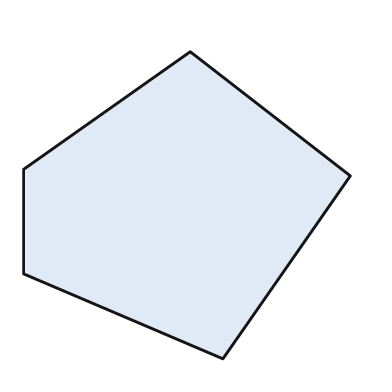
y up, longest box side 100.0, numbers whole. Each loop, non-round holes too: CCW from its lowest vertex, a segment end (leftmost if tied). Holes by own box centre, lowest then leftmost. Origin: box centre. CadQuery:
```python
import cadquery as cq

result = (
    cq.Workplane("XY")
    .moveTo(11.0, -47.0)
    .lineTo(50.0, 9.0)
    .lineTo(1.0, 47.0)
    .lineTo(-50.0, 11.0)
    .lineTo(-50.0, -21.0)
    .close()
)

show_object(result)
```